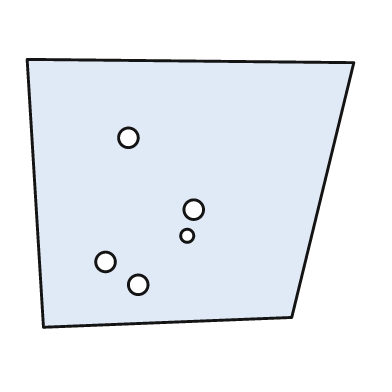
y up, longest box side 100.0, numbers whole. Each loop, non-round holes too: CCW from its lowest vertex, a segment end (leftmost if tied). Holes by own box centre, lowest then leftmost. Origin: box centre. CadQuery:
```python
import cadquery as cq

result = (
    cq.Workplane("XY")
    .moveTo(-45.0, -41.0)
    .lineTo(31.0, -38.0)
    .lineTo(50.0, 40.0)
    .lineTo(-50.0, 41.0)
    .close()
    .moveTo(-16.0, -28.0)
    .circle(3.0)
    .moveTo(-26.0, -21.0)
    .circle(3.0)
    .moveTo(-1.0, -13.0)
    .circle(2.0)
    .moveTo(1.0, -5.0)
    .circle(3.0)
    .moveTo(-19.0, 17.0)
    .circle(3.0)
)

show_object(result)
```